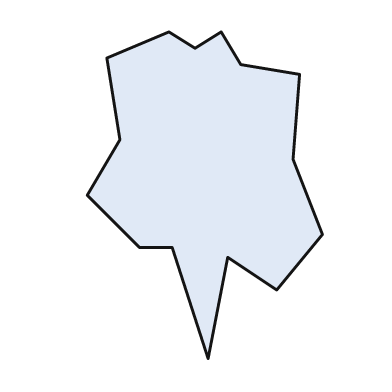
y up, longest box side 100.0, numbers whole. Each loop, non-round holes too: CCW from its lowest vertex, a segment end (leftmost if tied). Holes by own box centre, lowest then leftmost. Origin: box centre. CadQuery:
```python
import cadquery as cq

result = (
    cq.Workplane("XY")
    .moveTo(1.0, -50.0)
    .lineTo(7.0, -19.0)
    .lineTo(22.0, -29.0)
    .lineTo(36.0, -12.0)
    .lineTo(27.0, 11.0)
    .lineTo(29.0, 37.0)
    .lineTo(11.0, 40.0)
    .lineTo(5.0, 50.0)
    .lineTo(-3.0, 45.0)
    .lineTo(-11.0, 50.0)
    .lineTo(-30.0, 42.0)
    .lineTo(-26.0, 17.0)
    .lineTo(-36.0, 0.0)
    .lineTo(-20.0, -16.0)
    .lineTo(-10.0, -16.0)
    .close()
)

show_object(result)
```